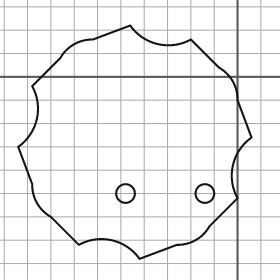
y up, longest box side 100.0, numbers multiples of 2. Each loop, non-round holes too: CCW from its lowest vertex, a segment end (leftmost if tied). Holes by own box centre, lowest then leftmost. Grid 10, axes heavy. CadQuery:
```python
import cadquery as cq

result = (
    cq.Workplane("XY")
    .moveTo(-42.0, -78.0)
    .lineTo(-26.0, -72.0)
    .threePointArc((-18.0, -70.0), (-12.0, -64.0))
    .lineTo(0.0, -52.0)
    .threePointArc((-2.0, -38.0), (6.0, -26.0))
    .lineTo(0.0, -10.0)
    .threePointArc((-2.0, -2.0), (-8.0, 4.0))
    .lineTo(-20.0, 16.0)
    .threePointArc((-34.0, 14.0), (-46.0, 22.0))
    .lineTo(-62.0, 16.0)
    .threePointArc((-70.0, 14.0), (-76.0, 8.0))
    .lineTo(-88.0, -4.0)
    .threePointArc((-86.0, -18.0), (-94.0, -30.0))
    .lineTo(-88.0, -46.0)
    .threePointArc((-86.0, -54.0), (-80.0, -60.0))
    .lineTo(-68.0, -72.0)
    .threePointArc((-54.0, -70.0), (-42.0, -78.0))
    .close()
    .moveTo(-48.0, -50.0)
    .circle(4.0)
    .moveTo(-14.0, -50.0)
    .circle(4.0)
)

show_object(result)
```